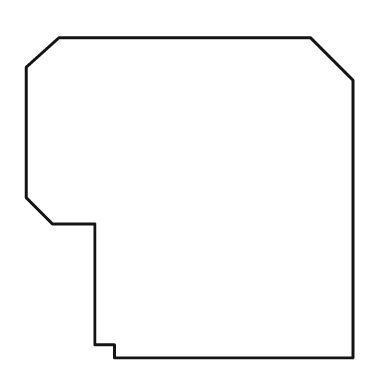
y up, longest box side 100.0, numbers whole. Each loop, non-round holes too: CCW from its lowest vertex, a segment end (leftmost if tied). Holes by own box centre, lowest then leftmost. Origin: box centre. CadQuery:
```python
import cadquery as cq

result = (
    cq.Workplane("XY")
    .moveTo(-23.0, -49.0)
    .lineTo(50.0, -49.0)
    .lineTo(50.0, 36.0)
    .lineTo(37.0, 49.0)
    .lineTo(-40.0, 49.0)
    .lineTo(-50.0, 40.0)
    .lineTo(-50.0, 0.0)
    .lineTo(-42.0, -8.0)
    .lineTo(-29.0, -8.0)
    .lineTo(-29.0, -45.0)
    .lineTo(-23.0, -45.0)
    .close()
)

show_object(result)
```